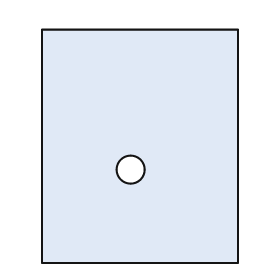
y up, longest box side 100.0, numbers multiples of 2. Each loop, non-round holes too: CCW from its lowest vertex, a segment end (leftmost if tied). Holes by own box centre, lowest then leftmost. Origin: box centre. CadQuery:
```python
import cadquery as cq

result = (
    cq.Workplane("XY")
    .moveTo(-42.0, -50.0)
    .lineTo(42.0, -50.0)
    .lineTo(42.0, 50.0)
    .lineTo(-42.0, 50.0)
    .close()
    .moveTo(-4.0, -10.0)
    .circle(6.0)
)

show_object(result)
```